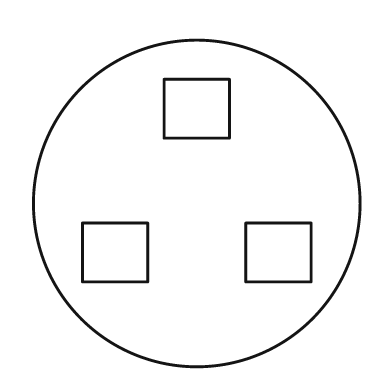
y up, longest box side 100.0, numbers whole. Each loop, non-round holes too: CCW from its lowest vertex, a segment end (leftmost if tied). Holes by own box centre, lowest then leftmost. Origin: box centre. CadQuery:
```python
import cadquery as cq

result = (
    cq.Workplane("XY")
    .moveTo(0.0, 0.0)
    .circle(50.0)
    .moveTo(-35.0, -24.0)
    .lineTo(-15.0, -24.0)
    .lineTo(-15.0, -6.0)
    .lineTo(-35.0, -6.0)
    .close()
    .moveTo(15.0, -24.0)
    .lineTo(35.0, -24.0)
    .lineTo(35.0, -6.0)
    .lineTo(15.0, -6.0)
    .close()
    .moveTo(-10.0, 20.0)
    .lineTo(10.0, 20.0)
    .lineTo(10.0, 38.0)
    .lineTo(-10.0, 38.0)
    .close()
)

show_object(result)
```